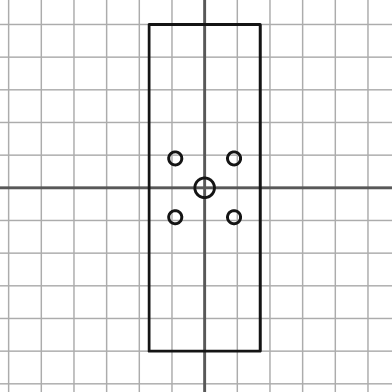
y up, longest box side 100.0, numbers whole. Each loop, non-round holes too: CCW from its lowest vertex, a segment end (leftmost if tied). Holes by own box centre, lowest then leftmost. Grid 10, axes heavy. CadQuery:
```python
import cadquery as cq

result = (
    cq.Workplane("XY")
    .moveTo(-17.0, -50.0)
    .lineTo(17.0, -50.0)
    .lineTo(17.0, 50.0)
    .lineTo(-17.0, 50.0)
    .close()
    .moveTo(-9.0, -9.0)
    .circle(2.0)
    .moveTo(9.0, -9.0)
    .circle(2.0)
    .moveTo(0.0, 0.0)
    .circle(3.0)
    .moveTo(-9.0, 9.0)
    .circle(2.0)
    .moveTo(9.0, 9.0)
    .circle(2.0)
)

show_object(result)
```